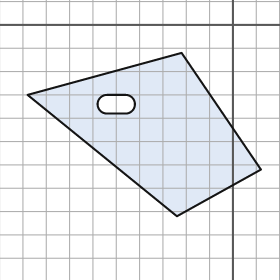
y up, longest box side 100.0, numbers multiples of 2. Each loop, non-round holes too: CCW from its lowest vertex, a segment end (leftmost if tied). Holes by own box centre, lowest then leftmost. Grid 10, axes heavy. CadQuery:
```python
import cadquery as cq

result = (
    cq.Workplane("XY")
    .moveTo(-24.0, -82.0)
    .lineTo(12.0, -62.0)
    .lineTo(-22.0, -12.0)
    .lineTo(-88.0, -30.0)
    .close()
    .moveTo(-54.0, -38.0)
    .lineTo(-46.0, -38.0)
    .threePointArc((-42.0, -34.0), (-46.0, -30.0))
    .lineTo(-54.0, -30.0)
    .threePointArc((-58.0, -34.0), (-54.0, -38.0))
    .close()
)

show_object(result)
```